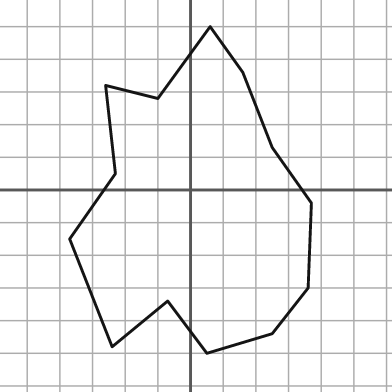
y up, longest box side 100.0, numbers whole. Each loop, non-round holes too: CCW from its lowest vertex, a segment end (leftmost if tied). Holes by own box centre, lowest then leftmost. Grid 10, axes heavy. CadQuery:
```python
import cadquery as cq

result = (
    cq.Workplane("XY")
    .moveTo(5.0, -50.0)
    .lineTo(25.0, -44.0)
    .lineTo(36.0, -30.0)
    .lineTo(37.0, -4.0)
    .lineTo(25.0, 13.0)
    .lineTo(16.0, 36.0)
    .lineTo(6.0, 50.0)
    .lineTo(-10.0, 28.0)
    .lineTo(-26.0, 32.0)
    .lineTo(-23.0, 5.0)
    .lineTo(-37.0, -15.0)
    .lineTo(-24.0, -48.0)
    .lineTo(-7.0, -34.0)
    .close()
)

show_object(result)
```